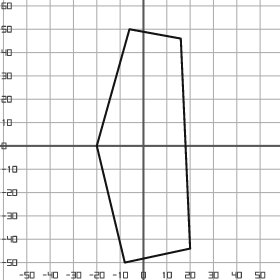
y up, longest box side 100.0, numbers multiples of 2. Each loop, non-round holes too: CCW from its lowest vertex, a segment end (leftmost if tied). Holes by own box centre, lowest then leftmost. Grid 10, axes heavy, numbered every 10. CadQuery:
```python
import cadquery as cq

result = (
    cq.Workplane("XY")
    .moveTo(-8.0, -50.0)
    .lineTo(20.0, -44.0)
    .lineTo(16.0, 46.0)
    .lineTo(-6.0, 50.0)
    .lineTo(-20.0, 0.0)
    .close()
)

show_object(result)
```